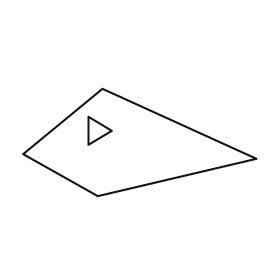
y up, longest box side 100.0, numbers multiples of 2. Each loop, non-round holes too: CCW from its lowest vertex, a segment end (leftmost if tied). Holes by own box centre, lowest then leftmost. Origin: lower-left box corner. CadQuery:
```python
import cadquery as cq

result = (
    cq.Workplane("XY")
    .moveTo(32.0, 0.0)
    .lineTo(100.0, 16.0)
    .lineTo(34.0, 46.0)
    .lineTo(0.0, 18.0)
    .close()
    .moveTo(28.0, 22.0)
    .lineTo(38.0, 28.0)
    .lineTo(28.0, 34.0)
    .close()
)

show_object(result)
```